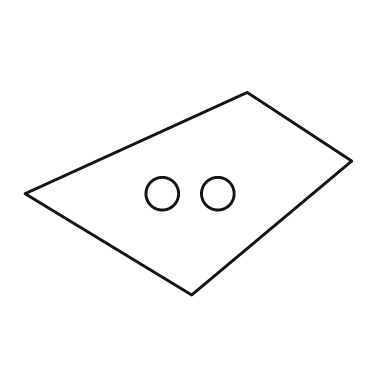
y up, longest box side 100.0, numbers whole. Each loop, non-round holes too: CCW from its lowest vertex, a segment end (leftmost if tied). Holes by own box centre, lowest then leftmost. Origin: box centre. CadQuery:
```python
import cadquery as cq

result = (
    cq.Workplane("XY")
    .moveTo(1.0, -31.0)
    .lineTo(50.0, 10.0)
    .lineTo(18.0, 31.0)
    .lineTo(-50.0, 0.0)
    .close()
    .moveTo(-8.0, 0.0)
    .circle(5.0)
    .moveTo(9.0, 0.0)
    .circle(5.0)
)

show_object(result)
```